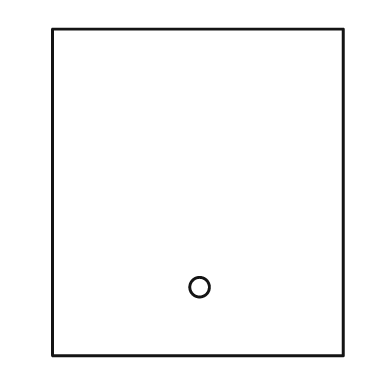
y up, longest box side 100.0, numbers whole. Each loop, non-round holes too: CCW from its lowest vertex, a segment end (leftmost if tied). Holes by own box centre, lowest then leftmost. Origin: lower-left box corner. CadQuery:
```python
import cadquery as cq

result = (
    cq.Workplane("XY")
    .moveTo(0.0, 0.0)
    .lineTo(89.0, 0.0)
    .lineTo(89.0, 100.0)
    .lineTo(0.0, 100.0)
    .close()
    .moveTo(45.0, 21.0)
    .circle(3.0)
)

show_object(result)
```